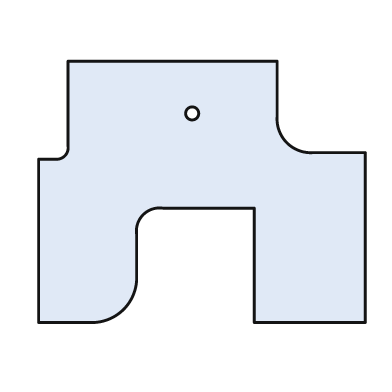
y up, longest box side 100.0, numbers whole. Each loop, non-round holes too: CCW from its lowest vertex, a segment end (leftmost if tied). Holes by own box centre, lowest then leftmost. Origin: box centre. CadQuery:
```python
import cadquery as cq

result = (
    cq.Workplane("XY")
    .moveTo(-50.0, -40.0)
    .lineTo(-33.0, -40.0)
    .threePointArc((-24.0, -36.0), (-20.0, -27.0))
    .lineTo(-20.0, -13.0)
    .threePointArc((-18.0, -7.0), (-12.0, -5.0))
    .lineTo(16.0, -5.0)
    .lineTo(16.0, -40.0)
    .lineTo(50.0, -40.0)
    .lineTo(50.0, 12.0)
    .lineTo(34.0, 12.0)
    .threePointArc((26.0, 15.0), (23.0, 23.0))
    .lineTo(23.0, 40.0)
    .lineTo(-41.0, 40.0)
    .lineTo(-41.0, 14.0)
    .threePointArc((-42.0, 11.0), (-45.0, 10.0))
    .lineTo(-50.0, 10.0)
    .close()
    .moveTo(-3.0, 24.0)
    .circle(2.0)
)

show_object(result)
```